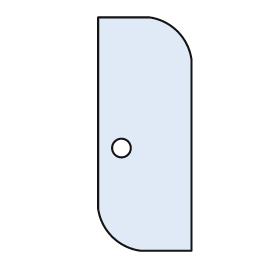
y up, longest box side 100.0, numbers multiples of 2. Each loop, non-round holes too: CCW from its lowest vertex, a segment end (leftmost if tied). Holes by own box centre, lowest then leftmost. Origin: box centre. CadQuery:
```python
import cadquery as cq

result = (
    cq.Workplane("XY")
    .moveTo(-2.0, -50.0)
    .lineTo(20.0, -50.0)
    .lineTo(20.0, 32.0)
    .threePointArc((14.0, 44.0), (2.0, 50.0))
    .lineTo(-20.0, 50.0)
    .lineTo(-20.0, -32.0)
    .threePointArc((-14.0, -44.0), (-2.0, -50.0))
    .close()
    .moveTo(-10.0, -6.0)
    .circle(4.0)
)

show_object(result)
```